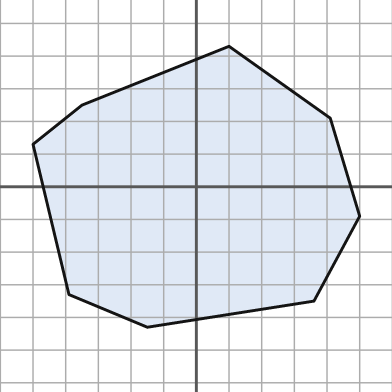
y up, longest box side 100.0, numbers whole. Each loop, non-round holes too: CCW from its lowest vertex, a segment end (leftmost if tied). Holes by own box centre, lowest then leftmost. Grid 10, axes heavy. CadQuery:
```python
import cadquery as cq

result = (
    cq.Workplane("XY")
    .moveTo(-15.0, -43.0)
    .lineTo(36.0, -35.0)
    .lineTo(50.0, -9.0)
    .lineTo(41.0, 21.0)
    .lineTo(10.0, 43.0)
    .lineTo(-35.0, 25.0)
    .lineTo(-50.0, 13.0)
    .lineTo(-39.0, -33.0)
    .close()
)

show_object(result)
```